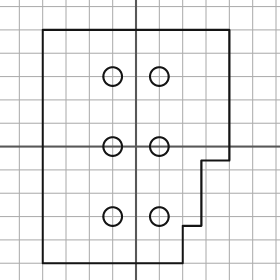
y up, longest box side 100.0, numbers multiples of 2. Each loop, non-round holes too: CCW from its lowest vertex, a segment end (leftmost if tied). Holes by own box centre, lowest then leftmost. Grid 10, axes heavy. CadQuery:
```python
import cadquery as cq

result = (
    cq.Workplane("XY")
    .moveTo(-40.0, -50.0)
    .lineTo(20.0, -50.0)
    .lineTo(20.0, -34.0)
    .lineTo(28.0, -34.0)
    .lineTo(28.0, -6.0)
    .lineTo(40.0, -6.0)
    .lineTo(40.0, 50.0)
    .lineTo(-40.0, 50.0)
    .close()
    .moveTo(-10.0, -30.0)
    .circle(4.0)
    .moveTo(10.0, -30.0)
    .circle(4.0)
    .moveTo(-10.0, 0.0)
    .circle(4.0)
    .moveTo(10.0, 0.0)
    .circle(4.0)
    .moveTo(-10.0, 30.0)
    .circle(4.0)
    .moveTo(10.0, 30.0)
    .circle(4.0)
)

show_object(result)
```